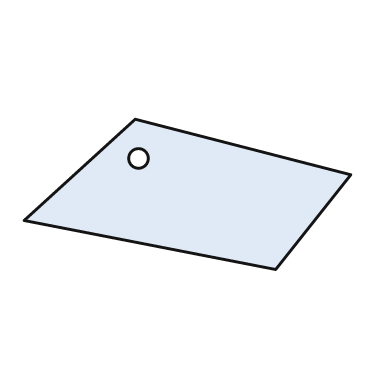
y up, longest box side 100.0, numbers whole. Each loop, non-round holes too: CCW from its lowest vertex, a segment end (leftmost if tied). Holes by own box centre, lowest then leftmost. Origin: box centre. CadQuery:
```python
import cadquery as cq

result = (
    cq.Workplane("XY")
    .moveTo(27.0, -23.0)
    .lineTo(50.0, 6.0)
    .lineTo(-16.0, 23.0)
    .lineTo(-50.0, -8.0)
    .close()
    .moveTo(-15.0, 11.0)
    .circle(3.0)
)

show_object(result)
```